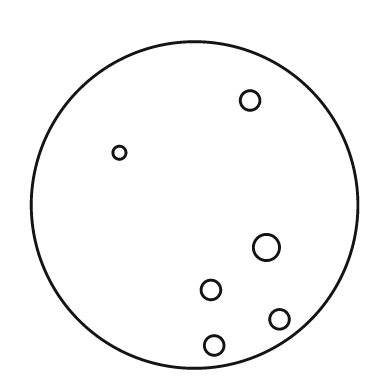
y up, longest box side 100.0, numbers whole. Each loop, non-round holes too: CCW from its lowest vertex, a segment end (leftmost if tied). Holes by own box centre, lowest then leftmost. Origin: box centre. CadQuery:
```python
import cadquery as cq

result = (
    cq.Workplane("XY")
    .moveTo(0.0, 0.0)
    .circle(50.0)
    .moveTo(6.0, -43.0)
    .circle(3.0)
    .moveTo(26.0, -35.0)
    .circle(3.0)
    .moveTo(5.0, -26.0)
    .circle(3.0)
    .moveTo(22.0, -13.0)
    .circle(4.0)
    .moveTo(-23.0, 16.0)
    .circle(2.0)
    .moveTo(17.0, 32.0)
    .circle(3.0)
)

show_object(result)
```